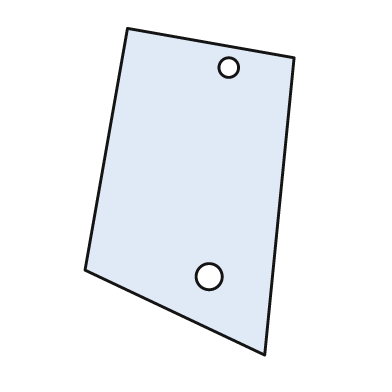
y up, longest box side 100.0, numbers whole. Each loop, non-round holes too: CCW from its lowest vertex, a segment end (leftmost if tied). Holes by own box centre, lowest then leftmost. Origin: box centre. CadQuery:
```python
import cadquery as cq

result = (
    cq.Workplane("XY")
    .moveTo(23.0, -50.0)
    .lineTo(32.0, 41.0)
    .lineTo(-19.0, 50.0)
    .lineTo(-32.0, -24.0)
    .close()
    .moveTo(6.0, -26.0)
    .circle(4.0)
    .moveTo(12.0, 38.0)
    .circle(3.0)
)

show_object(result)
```